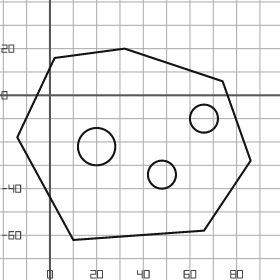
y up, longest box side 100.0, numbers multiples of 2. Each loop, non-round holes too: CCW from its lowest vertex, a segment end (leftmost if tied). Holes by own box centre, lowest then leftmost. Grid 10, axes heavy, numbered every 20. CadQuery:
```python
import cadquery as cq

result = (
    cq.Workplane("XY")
    .moveTo(10.0, -62.0)
    .lineTo(66.0, -58.0)
    .lineTo(86.0, -28.0)
    .lineTo(74.0, 6.0)
    .lineTo(32.0, 20.0)
    .lineTo(2.0, 16.0)
    .lineTo(-14.0, -18.0)
    .close()
    .moveTo(48.0, -34.0)
    .circle(6.0)
    .moveTo(20.0, -22.0)
    .circle(8.0)
    .moveTo(66.0, -10.0)
    .circle(6.0)
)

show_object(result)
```